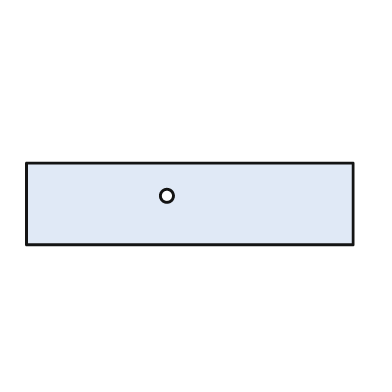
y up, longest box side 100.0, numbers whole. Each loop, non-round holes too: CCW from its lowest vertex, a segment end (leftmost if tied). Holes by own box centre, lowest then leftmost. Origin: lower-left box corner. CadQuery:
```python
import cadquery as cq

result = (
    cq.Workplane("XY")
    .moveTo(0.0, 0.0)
    .lineTo(100.0, 0.0)
    .lineTo(100.0, 25.0)
    .lineTo(0.0, 25.0)
    .close()
    .moveTo(43.0, 15.0)
    .circle(2.0)
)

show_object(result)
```